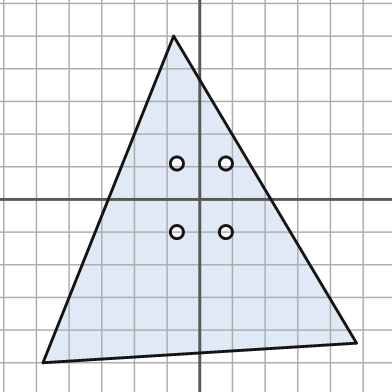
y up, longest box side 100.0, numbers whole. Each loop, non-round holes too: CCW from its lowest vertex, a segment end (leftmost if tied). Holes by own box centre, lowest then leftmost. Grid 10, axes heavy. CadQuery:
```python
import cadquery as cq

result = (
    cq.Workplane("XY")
    .moveTo(-48.0, -50.0)
    .lineTo(48.0, -44.0)
    .lineTo(-8.0, 50.0)
    .close()
    .moveTo(-7.0, -10.0)
    .circle(2.0)
    .moveTo(8.0, -10.0)
    .circle(2.0)
    .moveTo(-7.0, 11.0)
    .circle(2.0)
    .moveTo(8.0, 11.0)
    .circle(2.0)
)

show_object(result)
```